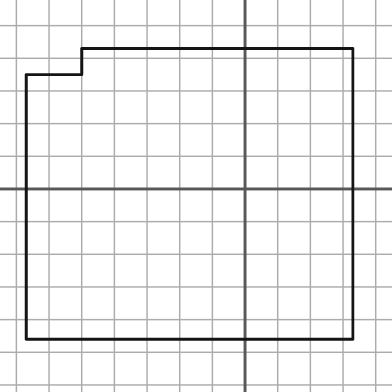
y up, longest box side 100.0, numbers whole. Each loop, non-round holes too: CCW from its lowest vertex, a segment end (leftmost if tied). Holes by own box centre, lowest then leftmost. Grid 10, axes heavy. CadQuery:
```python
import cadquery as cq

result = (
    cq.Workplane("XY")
    .moveTo(-67.0, -46.0)
    .lineTo(33.0, -46.0)
    .lineTo(33.0, 43.0)
    .lineTo(-50.0, 43.0)
    .lineTo(-50.0, 35.0)
    .lineTo(-67.0, 35.0)
    .close()
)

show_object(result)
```